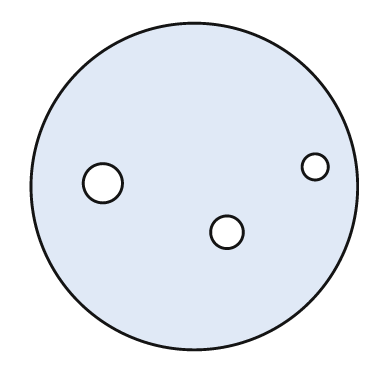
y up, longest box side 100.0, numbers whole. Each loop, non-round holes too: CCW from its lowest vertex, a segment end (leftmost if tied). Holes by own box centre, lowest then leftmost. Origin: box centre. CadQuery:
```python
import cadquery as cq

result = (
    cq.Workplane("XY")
    .moveTo(0.0, 0.0)
    .circle(50.0)
    .moveTo(10.0, -14.0)
    .circle(5.0)
    .moveTo(-28.0, 1.0)
    .circle(6.0)
    .moveTo(37.0, 6.0)
    .circle(4.0)
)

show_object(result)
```